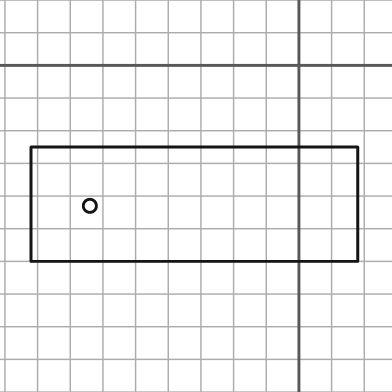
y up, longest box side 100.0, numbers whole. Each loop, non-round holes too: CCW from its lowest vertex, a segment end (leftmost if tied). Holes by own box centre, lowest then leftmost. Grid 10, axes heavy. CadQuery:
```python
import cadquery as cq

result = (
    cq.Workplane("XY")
    .moveTo(-82.0, -60.0)
    .lineTo(18.0, -60.0)
    .lineTo(18.0, -25.0)
    .lineTo(-82.0, -25.0)
    .close()
    .moveTo(-64.0, -43.0)
    .circle(2.0)
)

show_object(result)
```